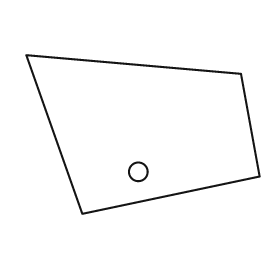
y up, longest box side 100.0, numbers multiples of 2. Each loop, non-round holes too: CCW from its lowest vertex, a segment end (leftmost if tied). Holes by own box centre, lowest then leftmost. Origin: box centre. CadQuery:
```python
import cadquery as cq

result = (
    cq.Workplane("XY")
    .moveTo(-26.0, -34.0)
    .lineTo(50.0, -18.0)
    .lineTo(42.0, 26.0)
    .lineTo(-50.0, 34.0)
    .close()
    .moveTo(-2.0, -16.0)
    .circle(4.0)
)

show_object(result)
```